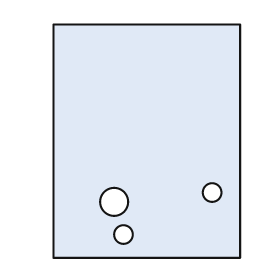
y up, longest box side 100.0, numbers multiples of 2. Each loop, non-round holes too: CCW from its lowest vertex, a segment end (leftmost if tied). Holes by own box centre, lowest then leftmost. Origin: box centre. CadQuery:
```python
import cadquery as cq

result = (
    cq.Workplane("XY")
    .moveTo(-40.0, -50.0)
    .lineTo(40.0, -50.0)
    .lineTo(40.0, 50.0)
    .lineTo(-40.0, 50.0)
    .close()
    .moveTo(-10.0, -40.0)
    .circle(4.0)
    .moveTo(-14.0, -26.0)
    .circle(6.0)
    .moveTo(28.0, -22.0)
    .circle(4.0)
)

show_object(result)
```